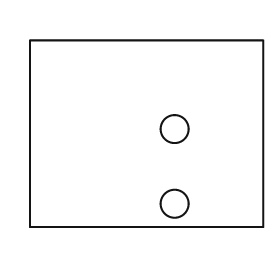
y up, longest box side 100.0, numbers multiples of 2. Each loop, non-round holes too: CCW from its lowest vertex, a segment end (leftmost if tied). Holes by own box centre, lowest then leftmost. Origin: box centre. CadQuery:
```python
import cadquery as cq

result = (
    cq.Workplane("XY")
    .moveTo(-50.0, -40.0)
    .lineTo(50.0, -40.0)
    .lineTo(50.0, 40.0)
    .lineTo(-50.0, 40.0)
    .close()
    .moveTo(12.0, -30.0)
    .circle(6.0)
    .moveTo(12.0, 2.0)
    .circle(6.0)
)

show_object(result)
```